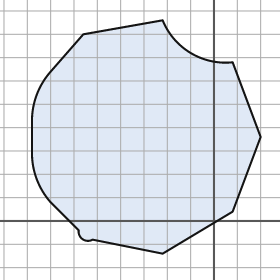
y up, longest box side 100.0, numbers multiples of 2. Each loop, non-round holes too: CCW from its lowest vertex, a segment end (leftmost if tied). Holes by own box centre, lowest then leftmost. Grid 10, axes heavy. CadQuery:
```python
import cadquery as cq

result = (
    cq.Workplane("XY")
    .moveTo(-22.0, -14.0)
    .lineTo(8.0, 4.0)
    .lineTo(20.0, 36.0)
    .lineTo(8.0, 68.0)
    .threePointArc((-10.0, 72.0), (-22.0, 86.0))
    .lineTo(-56.0, 80.0)
    .lineTo(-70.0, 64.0)
    .threePointArc((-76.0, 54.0), (-78.0, 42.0))
    .lineTo(-78.0, 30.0)
    .threePointArc((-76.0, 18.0), (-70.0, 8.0))
    .lineTo(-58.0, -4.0)
    .threePointArc((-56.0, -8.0), (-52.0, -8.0))
    .close()
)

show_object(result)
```